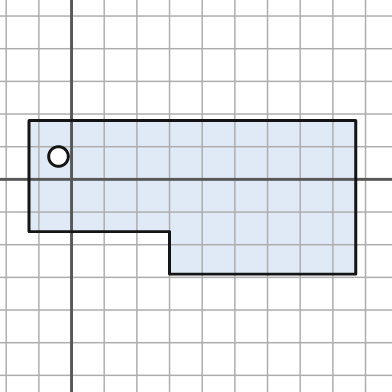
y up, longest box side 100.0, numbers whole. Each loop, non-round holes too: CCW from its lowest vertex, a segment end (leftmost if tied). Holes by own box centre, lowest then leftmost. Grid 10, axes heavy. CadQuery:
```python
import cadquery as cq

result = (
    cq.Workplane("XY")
    .moveTo(30.0, -29.0)
    .lineTo(87.0, -29.0)
    .lineTo(87.0, 18.0)
    .lineTo(-13.0, 18.0)
    .lineTo(-13.0, -16.0)
    .lineTo(30.0, -16.0)
    .close()
    .moveTo(-4.0, 7.0)
    .circle(3.0)
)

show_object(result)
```